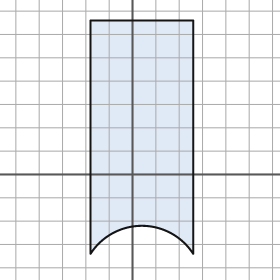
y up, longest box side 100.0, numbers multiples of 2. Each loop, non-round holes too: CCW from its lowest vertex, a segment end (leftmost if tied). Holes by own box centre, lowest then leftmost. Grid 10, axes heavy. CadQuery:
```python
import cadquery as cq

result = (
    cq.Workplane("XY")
    .moveTo(-18.0, -34.0)
    .threePointArc((4.0, -22.0), (26.0, -34.0))
    .lineTo(26.0, 66.0)
    .lineTo(-18.0, 66.0)
    .close()
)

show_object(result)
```